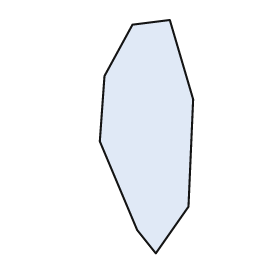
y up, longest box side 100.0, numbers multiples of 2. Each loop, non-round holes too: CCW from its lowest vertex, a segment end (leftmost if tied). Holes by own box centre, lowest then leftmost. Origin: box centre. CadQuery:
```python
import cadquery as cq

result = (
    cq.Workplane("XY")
    .moveTo(4.0, -50.0)
    .lineTo(18.0, -30.0)
    .lineTo(20.0, 16.0)
    .lineTo(10.0, 50.0)
    .lineTo(-6.0, 48.0)
    .lineTo(-18.0, 26.0)
    .lineTo(-20.0, -2.0)
    .lineTo(-4.0, -40.0)
    .close()
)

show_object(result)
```